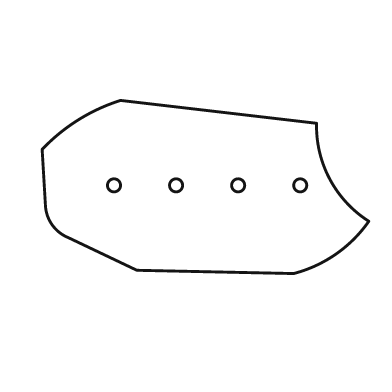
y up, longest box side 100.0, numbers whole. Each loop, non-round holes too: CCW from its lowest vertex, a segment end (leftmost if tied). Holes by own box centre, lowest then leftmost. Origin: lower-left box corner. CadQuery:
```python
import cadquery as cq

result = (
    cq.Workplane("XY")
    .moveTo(77.0, 0.0)
    .threePointArc((90.0, 6.0), (100.0, 16.0))
    .threePointArc((88.0, 29.0), (84.0, 46.0))
    .lineTo(24.0, 53.0)
    .threePointArc((11.0, 47.0), (0.0, 38.0))
    .lineTo(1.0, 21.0)
    .threePointArc((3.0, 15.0), (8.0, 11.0))
    .lineTo(29.0, 1.0)
    .close()
    .moveTo(22.0, 27.0)
    .circle(2.0)
    .moveTo(41.0, 27.0)
    .circle(2.0)
    .moveTo(60.0, 27.0)
    .circle(2.0)
    .moveTo(79.0, 27.0)
    .circle(2.0)
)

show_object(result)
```